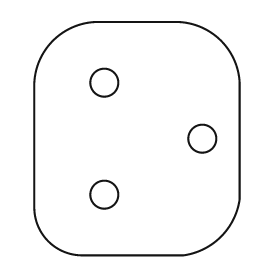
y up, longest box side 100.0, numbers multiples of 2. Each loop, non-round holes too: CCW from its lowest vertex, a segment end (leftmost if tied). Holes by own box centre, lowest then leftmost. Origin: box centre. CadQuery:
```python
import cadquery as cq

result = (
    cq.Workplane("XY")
    .moveTo(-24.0, -50.0)
    .lineTo(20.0, -50.0)
    .threePointArc((36.0, -42.0), (44.0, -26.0))
    .lineTo(44.0, 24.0)
    .threePointArc((36.0, 42.0), (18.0, 50.0))
    .lineTo(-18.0, 50.0)
    .threePointArc((-36.0, 42.0), (-44.0, 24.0))
    .lineTo(-44.0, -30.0)
    .threePointArc((-38.0, -44.0), (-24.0, -50.0))
    .close()
    .moveTo(-14.0, -24.0)
    .circle(6.0)
    .moveTo(28.0, 0.0)
    .circle(6.0)
    .moveTo(-14.0, 24.0)
    .circle(6.0)
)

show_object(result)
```